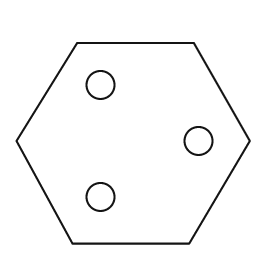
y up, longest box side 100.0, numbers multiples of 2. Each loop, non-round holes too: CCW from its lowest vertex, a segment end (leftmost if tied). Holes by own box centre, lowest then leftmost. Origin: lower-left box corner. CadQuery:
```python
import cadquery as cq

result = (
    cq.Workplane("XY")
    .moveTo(24.0, 0.0)
    .lineTo(74.0, 0.0)
    .lineTo(100.0, 44.0)
    .lineTo(76.0, 86.0)
    .lineTo(26.0, 86.0)
    .lineTo(0.0, 44.0)
    .close()
    .moveTo(36.0, 20.0)
    .circle(6.0)
    .moveTo(78.0, 44.0)
    .circle(6.0)
    .moveTo(36.0, 68.0)
    .circle(6.0)
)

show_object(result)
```